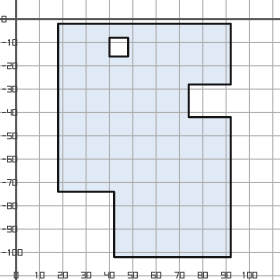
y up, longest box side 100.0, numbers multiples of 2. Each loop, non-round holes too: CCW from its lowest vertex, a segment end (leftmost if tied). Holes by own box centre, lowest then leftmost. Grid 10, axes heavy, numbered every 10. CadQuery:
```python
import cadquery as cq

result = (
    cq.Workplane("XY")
    .moveTo(42.0, -102.0)
    .lineTo(92.0, -102.0)
    .lineTo(92.0, -42.0)
    .lineTo(74.0, -42.0)
    .lineTo(74.0, -28.0)
    .lineTo(92.0, -28.0)
    .lineTo(92.0, -2.0)
    .lineTo(18.0, -2.0)
    .lineTo(18.0, -74.0)
    .lineTo(42.0, -74.0)
    .close()
    .moveTo(40.0, -16.0)
    .lineTo(48.0, -16.0)
    .lineTo(48.0, -8.0)
    .lineTo(40.0, -8.0)
    .close()
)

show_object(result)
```